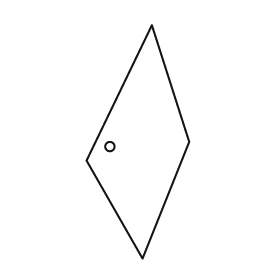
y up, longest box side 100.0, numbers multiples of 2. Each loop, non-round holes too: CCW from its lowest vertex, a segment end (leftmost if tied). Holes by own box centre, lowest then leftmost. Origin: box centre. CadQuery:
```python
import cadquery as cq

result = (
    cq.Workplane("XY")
    .moveTo(2.0, -50.0)
    .lineTo(22.0, 0.0)
    .lineTo(6.0, 50.0)
    .lineTo(-22.0, -8.0)
    .close()
    .moveTo(-12.0, -2.0)
    .circle(2.0)
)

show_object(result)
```